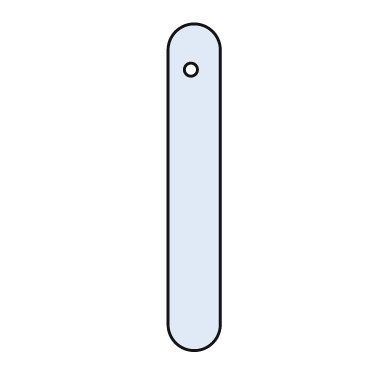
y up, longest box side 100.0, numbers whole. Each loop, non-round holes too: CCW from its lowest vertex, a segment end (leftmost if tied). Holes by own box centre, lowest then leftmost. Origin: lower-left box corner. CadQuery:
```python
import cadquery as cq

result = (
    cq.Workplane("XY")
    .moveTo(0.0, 8.0)
    .threePointArc((8.0, 0.0), (16.0, 8.0))
    .lineTo(16.0, 92.0)
    .threePointArc((8.0, 100.0), (0.0, 92.0))
    .close()
    .moveTo(7.0, 86.0)
    .circle(2.0)
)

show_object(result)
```